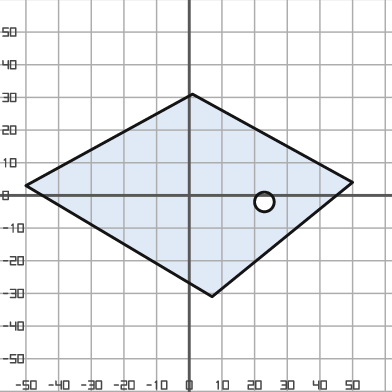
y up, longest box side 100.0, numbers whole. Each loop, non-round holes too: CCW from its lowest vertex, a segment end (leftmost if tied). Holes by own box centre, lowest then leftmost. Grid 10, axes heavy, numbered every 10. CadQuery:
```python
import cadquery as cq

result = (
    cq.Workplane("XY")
    .moveTo(7.0, -31.0)
    .lineTo(50.0, 4.0)
    .lineTo(1.0, 31.0)
    .lineTo(-50.0, 3.0)
    .close()
    .moveTo(23.0, -2.0)
    .circle(3.0)
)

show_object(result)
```